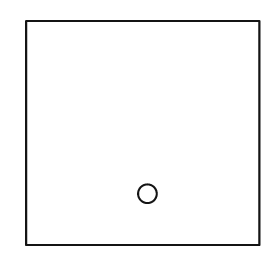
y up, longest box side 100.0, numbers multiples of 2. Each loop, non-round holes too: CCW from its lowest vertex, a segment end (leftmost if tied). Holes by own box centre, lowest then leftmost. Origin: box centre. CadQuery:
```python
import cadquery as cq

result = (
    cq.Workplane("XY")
    .moveTo(-50.0, -48.0)
    .lineTo(50.0, -48.0)
    .lineTo(50.0, 48.0)
    .lineTo(-50.0, 48.0)
    .close()
    .moveTo(2.0, -26.0)
    .circle(4.0)
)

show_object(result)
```